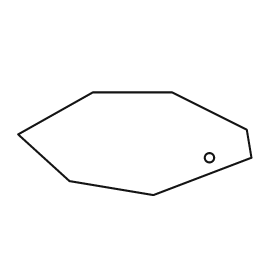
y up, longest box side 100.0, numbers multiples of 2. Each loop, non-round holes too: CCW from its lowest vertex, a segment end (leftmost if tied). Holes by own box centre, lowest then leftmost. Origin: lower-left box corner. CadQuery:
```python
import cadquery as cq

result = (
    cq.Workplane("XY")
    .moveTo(58.0, 0.0)
    .lineTo(100.0, 16.0)
    .lineTo(98.0, 28.0)
    .lineTo(66.0, 44.0)
    .lineTo(32.0, 44.0)
    .lineTo(0.0, 26.0)
    .lineTo(22.0, 6.0)
    .close()
    .moveTo(82.0, 16.0)
    .circle(2.0)
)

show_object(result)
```